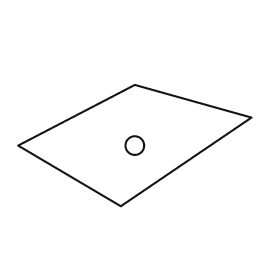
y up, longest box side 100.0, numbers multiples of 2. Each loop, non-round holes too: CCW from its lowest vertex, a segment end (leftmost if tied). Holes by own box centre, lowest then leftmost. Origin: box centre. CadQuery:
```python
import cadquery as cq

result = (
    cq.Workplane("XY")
    .moveTo(-6.0, -26.0)
    .lineTo(50.0, 12.0)
    .lineTo(0.0, 26.0)
    .lineTo(-50.0, 0.0)
    .close()
    .moveTo(0.0, 0.0)
    .circle(4.0)
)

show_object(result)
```